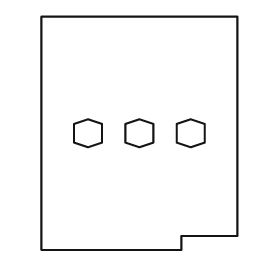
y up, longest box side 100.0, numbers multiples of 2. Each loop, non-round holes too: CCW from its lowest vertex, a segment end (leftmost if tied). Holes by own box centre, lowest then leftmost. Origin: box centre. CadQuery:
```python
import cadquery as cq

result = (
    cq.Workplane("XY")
    .moveTo(-42.0, -50.0)
    .lineTo(18.0, -50.0)
    .lineTo(18.0, -44.0)
    .lineTo(42.0, -44.0)
    .lineTo(42.0, 50.0)
    .lineTo(-42.0, 50.0)
    .close()
    .moveTo(-22.0, -6.0)
    .lineTo(-16.0, -4.0)
    .lineTo(-16.0, 4.0)
    .lineTo(-22.0, 6.0)
    .lineTo(-28.0, 4.0)
    .lineTo(-28.0, -4.0)
    .close()
    .moveTo(0.0, -6.0)
    .lineTo(6.0, -4.0)
    .lineTo(6.0, 4.0)
    .lineTo(0.0, 6.0)
    .lineTo(-6.0, 4.0)
    .lineTo(-6.0, -4.0)
    .close()
    .moveTo(22.0, -6.0)
    .lineTo(28.0, -4.0)
    .lineTo(28.0, 4.0)
    .lineTo(22.0, 6.0)
    .lineTo(16.0, 4.0)
    .lineTo(16.0, -4.0)
    .close()
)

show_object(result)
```